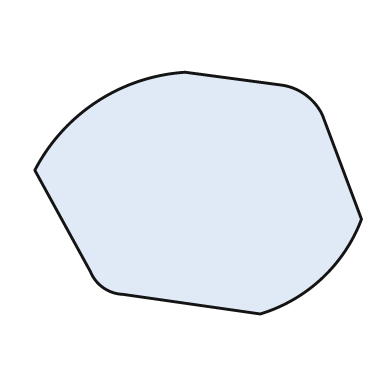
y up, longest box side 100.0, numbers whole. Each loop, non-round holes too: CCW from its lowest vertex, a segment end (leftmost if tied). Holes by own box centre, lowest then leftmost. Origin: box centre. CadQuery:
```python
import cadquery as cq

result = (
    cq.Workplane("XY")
    .moveTo(19.0, -37.0)
    .threePointArc((38.0, -26.0), (50.0, -8.0))
    .lineTo(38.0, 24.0)
    .threePointArc((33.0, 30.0), (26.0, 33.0))
    .lineTo(-4.0, 37.0)
    .threePointArc((-31.0, 28.0), (-50.0, 7.0))
    .lineTo(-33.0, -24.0)
    .threePointArc((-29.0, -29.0), (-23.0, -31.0))
    .close()
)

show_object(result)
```